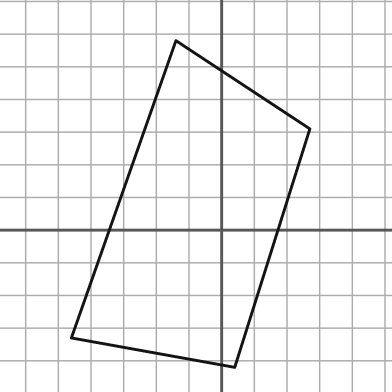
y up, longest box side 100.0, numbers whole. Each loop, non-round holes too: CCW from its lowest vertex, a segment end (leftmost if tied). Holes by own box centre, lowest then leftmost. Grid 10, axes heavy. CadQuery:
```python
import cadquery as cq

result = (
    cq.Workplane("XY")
    .moveTo(4.0, -42.0)
    .lineTo(27.0, 31.0)
    .lineTo(-14.0, 58.0)
    .lineTo(-46.0, -33.0)
    .close()
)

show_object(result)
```